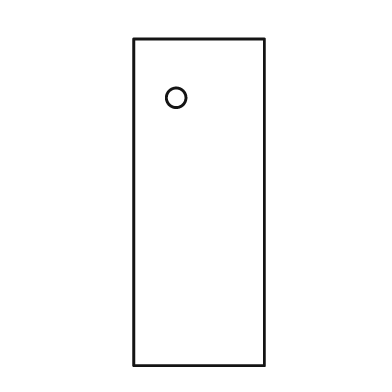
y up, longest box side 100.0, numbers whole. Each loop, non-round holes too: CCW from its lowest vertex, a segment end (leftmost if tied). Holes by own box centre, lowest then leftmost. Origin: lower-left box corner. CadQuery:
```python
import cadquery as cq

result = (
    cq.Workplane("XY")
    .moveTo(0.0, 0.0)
    .lineTo(40.0, 0.0)
    .lineTo(40.0, 100.0)
    .lineTo(0.0, 100.0)
    .close()
    .moveTo(13.0, 82.0)
    .circle(3.0)
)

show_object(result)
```